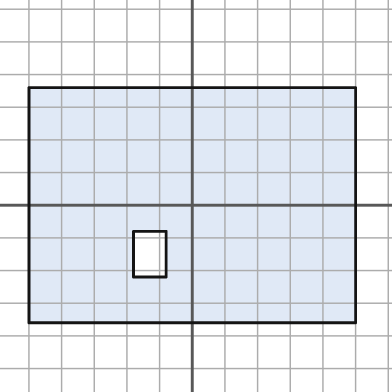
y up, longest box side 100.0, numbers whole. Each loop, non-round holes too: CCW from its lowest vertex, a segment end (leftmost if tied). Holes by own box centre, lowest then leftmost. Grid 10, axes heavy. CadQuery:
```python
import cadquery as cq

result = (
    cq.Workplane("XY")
    .moveTo(-50.0, -36.0)
    .lineTo(50.0, -36.0)
    .lineTo(50.0, 36.0)
    .lineTo(-50.0, 36.0)
    .close()
    .moveTo(-18.0, -22.0)
    .lineTo(-8.0, -22.0)
    .lineTo(-8.0, -8.0)
    .lineTo(-18.0, -8.0)
    .close()
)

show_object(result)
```